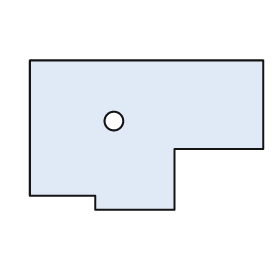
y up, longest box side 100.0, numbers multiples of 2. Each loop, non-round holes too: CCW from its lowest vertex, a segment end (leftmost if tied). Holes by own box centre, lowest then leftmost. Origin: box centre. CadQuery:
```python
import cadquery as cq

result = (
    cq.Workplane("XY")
    .moveTo(-22.0, -32.0)
    .lineTo(12.0, -32.0)
    .lineTo(12.0, -6.0)
    .lineTo(50.0, -6.0)
    .lineTo(50.0, 32.0)
    .lineTo(-50.0, 32.0)
    .lineTo(-50.0, -26.0)
    .lineTo(-22.0, -26.0)
    .close()
    .moveTo(-14.0, 6.0)
    .circle(4.0)
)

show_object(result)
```